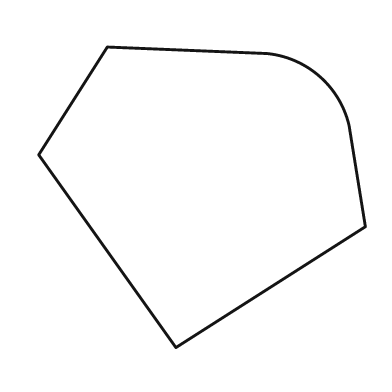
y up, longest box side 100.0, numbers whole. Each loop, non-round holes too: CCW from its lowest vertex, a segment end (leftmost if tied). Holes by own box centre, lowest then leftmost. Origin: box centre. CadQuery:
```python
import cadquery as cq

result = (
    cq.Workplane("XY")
    .moveTo(-8.0, -46.0)
    .lineTo(50.0, -9.0)
    .lineTo(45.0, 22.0)
    .threePointArc((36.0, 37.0), (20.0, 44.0))
    .lineTo(-29.0, 46.0)
    .lineTo(-50.0, 13.0)
    .close()
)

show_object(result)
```